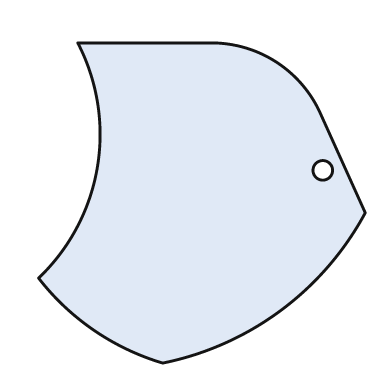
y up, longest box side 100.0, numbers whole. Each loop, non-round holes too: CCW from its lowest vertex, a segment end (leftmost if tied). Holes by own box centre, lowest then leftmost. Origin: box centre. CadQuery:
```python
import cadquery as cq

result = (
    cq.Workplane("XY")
    .moveTo(-12.0, -49.0)
    .threePointArc((24.0, -33.0), (50.0, -3.0))
    .lineTo(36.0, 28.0)
    .threePointArc((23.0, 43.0), (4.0, 49.0))
    .lineTo(-38.0, 49.0)
    .threePointArc((-32.0, 11.0), (-50.0, -23.0))
    .threePointArc((-33.0, -39.0), (-12.0, -49.0))
    .close()
    .moveTo(37.0, 10.0)
    .circle(3.0)
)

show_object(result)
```